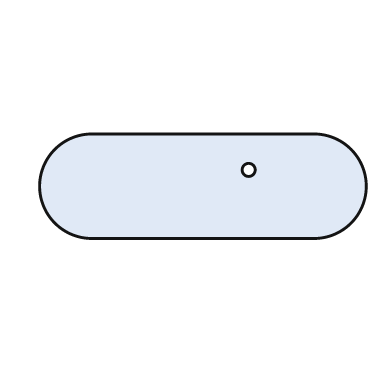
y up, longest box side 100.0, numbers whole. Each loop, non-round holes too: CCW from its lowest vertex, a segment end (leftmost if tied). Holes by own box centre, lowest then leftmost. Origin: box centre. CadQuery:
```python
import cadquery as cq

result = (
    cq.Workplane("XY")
    .moveTo(-34.0, -16.0)
    .lineTo(34.0, -16.0)
    .threePointArc((50.0, 0.0), (34.0, 16.0))
    .lineTo(-34.0, 16.0)
    .threePointArc((-50.0, 0.0), (-34.0, -16.0))
    .close()
    .moveTo(14.0, 5.0)
    .circle(2.0)
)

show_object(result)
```